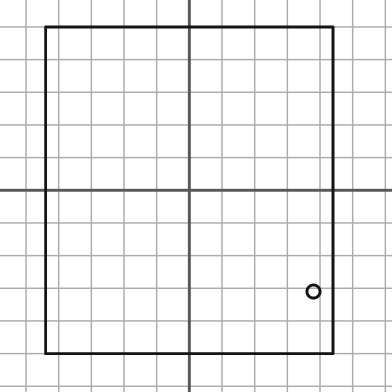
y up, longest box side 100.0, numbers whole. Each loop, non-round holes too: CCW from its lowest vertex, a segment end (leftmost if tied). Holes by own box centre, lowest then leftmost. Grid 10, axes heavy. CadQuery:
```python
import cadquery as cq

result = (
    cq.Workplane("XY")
    .moveTo(-44.0, -50.0)
    .lineTo(44.0, -50.0)
    .lineTo(44.0, 50.0)
    .lineTo(-44.0, 50.0)
    .close()
    .moveTo(38.0, -31.0)
    .circle(2.0)
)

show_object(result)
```